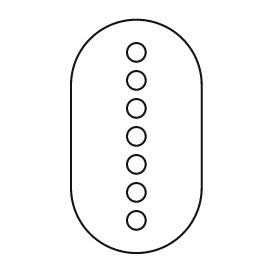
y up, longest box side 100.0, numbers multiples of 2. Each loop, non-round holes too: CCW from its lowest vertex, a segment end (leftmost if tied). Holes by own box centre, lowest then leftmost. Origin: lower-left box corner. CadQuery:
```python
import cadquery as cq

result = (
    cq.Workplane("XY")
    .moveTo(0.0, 28.0)
    .threePointArc((28.0, 0.0), (56.0, 28.0))
    .lineTo(56.0, 72.0)
    .threePointArc((28.0, 100.0), (0.0, 72.0))
    .close()
    .moveTo(28.0, 14.0)
    .circle(4.0)
    .moveTo(28.0, 26.0)
    .circle(4.0)
    .moveTo(28.0, 38.0)
    .circle(4.0)
    .moveTo(28.0, 50.0)
    .circle(4.0)
    .moveTo(28.0, 62.0)
    .circle(4.0)
    .moveTo(28.0, 74.0)
    .circle(4.0)
    .moveTo(28.0, 86.0)
    .circle(4.0)
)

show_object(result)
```